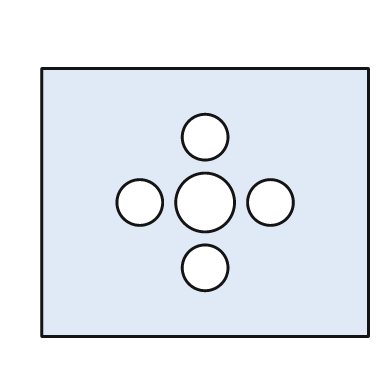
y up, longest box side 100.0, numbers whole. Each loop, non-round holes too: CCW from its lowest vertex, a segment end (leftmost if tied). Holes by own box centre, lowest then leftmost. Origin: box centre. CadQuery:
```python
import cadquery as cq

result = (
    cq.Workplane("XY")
    .moveTo(-50.0, -41.0)
    .lineTo(50.0, -41.0)
    .lineTo(50.0, 41.0)
    .lineTo(-50.0, 41.0)
    .close()
    .moveTo(0.0, -20.0)
    .circle(7.0)
    .moveTo(-20.0, 0.0)
    .circle(7.0)
    .moveTo(0.0, 0.0)
    .circle(9.0)
    .moveTo(20.0, 0.0)
    .circle(7.0)
    .moveTo(0.0, 20.0)
    .circle(7.0)
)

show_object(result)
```